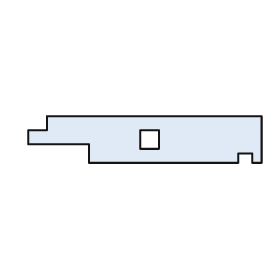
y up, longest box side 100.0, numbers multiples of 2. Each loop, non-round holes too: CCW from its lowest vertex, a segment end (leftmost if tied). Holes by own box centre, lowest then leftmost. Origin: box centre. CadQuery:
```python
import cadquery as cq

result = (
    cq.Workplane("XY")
    .moveTo(-24.0, -10.0)
    .lineTo(40.0, -10.0)
    .lineTo(40.0, -6.0)
    .lineTo(46.0, -6.0)
    .lineTo(46.0, -10.0)
    .lineTo(50.0, -10.0)
    .lineTo(50.0, 10.0)
    .lineTo(-42.0, 10.0)
    .lineTo(-42.0, 4.0)
    .lineTo(-50.0, 4.0)
    .lineTo(-50.0, -2.0)
    .lineTo(-24.0, -2.0)
    .close()
    .moveTo(-2.0, -4.0)
    .lineTo(6.0, -4.0)
    .lineTo(6.0, 4.0)
    .lineTo(-2.0, 4.0)
    .close()
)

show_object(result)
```